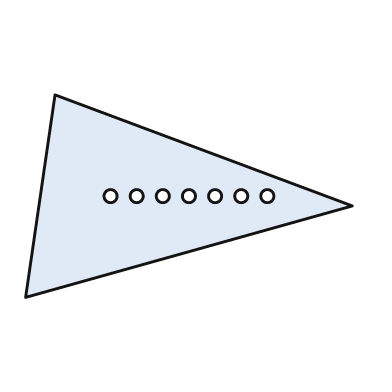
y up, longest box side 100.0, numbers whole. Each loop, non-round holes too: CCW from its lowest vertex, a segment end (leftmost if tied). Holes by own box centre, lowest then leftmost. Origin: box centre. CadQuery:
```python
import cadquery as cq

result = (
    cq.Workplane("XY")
    .moveTo(-50.0, -31.0)
    .lineTo(50.0, -3.0)
    .lineTo(-41.0, 31.0)
    .close()
    .moveTo(-24.0, 0.0)
    .circle(2.0)
    .moveTo(-16.0, 0.0)
    .circle(2.0)
    .moveTo(-8.0, 0.0)
    .circle(2.0)
    .moveTo(0.0, 0.0)
    .circle(2.0)
    .moveTo(8.0, 0.0)
    .circle(2.0)
    .moveTo(16.0, 0.0)
    .circle(2.0)
    .moveTo(24.0, 0.0)
    .circle(2.0)
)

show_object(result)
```